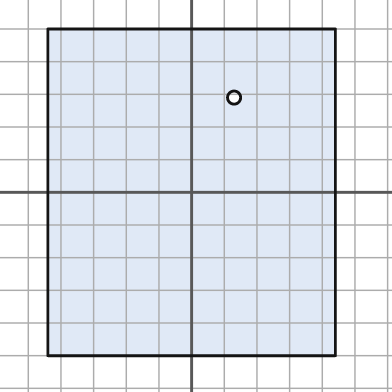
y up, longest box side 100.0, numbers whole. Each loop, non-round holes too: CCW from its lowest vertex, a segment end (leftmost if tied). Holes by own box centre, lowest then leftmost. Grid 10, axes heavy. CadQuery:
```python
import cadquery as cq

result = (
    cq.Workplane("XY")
    .moveTo(-44.0, -50.0)
    .lineTo(44.0, -50.0)
    .lineTo(44.0, 50.0)
    .lineTo(-44.0, 50.0)
    .close()
    .moveTo(13.0, 29.0)
    .circle(2.0)
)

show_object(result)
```